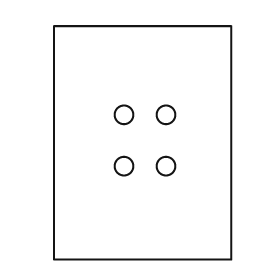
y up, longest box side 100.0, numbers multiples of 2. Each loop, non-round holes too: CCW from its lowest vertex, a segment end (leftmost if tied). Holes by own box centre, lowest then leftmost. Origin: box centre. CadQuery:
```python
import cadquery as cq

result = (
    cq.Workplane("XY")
    .moveTo(-38.0, -50.0)
    .lineTo(38.0, -50.0)
    .lineTo(38.0, 50.0)
    .lineTo(-38.0, 50.0)
    .close()
    .moveTo(-8.0, -10.0)
    .circle(4.0)
    .moveTo(10.0, -10.0)
    .circle(4.0)
    .moveTo(-8.0, 12.0)
    .circle(4.0)
    .moveTo(10.0, 12.0)
    .circle(4.0)
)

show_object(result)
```